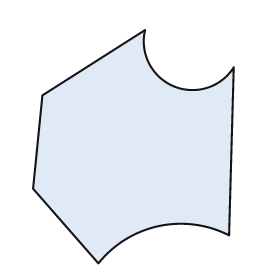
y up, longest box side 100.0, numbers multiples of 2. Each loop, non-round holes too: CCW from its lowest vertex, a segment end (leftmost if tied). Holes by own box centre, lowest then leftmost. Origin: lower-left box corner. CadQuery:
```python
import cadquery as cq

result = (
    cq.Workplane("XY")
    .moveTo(28.0, 0.0)
    .threePointArc((54.0, 16.0), (84.0, 12.0))
    .lineTo(86.0, 84.0)
    .threePointArc((60.0, 76.0), (48.0, 100.0))
    .lineTo(4.0, 72.0)
    .lineTo(0.0, 32.0)
    .close()
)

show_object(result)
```